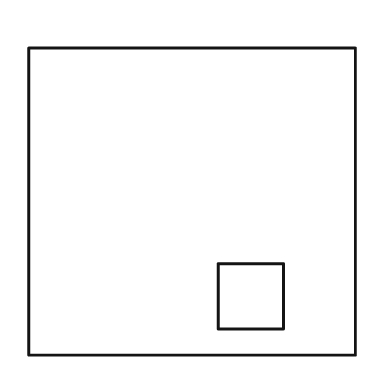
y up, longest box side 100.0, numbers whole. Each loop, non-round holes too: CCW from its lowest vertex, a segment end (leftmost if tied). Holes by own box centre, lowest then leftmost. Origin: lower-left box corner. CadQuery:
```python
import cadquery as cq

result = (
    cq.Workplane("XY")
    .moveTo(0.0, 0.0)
    .lineTo(100.0, 0.0)
    .lineTo(100.0, 94.0)
    .lineTo(0.0, 94.0)
    .close()
    .moveTo(58.0, 8.0)
    .lineTo(78.0, 8.0)
    .lineTo(78.0, 28.0)
    .lineTo(58.0, 28.0)
    .close()
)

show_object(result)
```